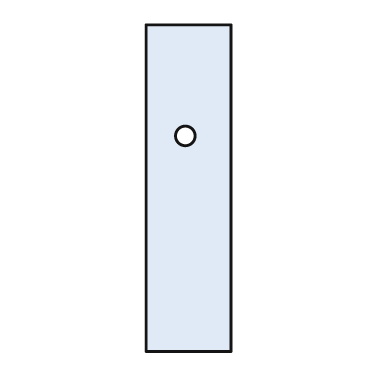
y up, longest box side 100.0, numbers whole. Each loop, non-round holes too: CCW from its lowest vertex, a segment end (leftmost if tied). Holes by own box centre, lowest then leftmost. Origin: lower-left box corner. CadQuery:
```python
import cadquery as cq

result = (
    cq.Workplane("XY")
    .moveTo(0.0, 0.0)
    .lineTo(26.0, 0.0)
    .lineTo(26.0, 100.0)
    .lineTo(0.0, 100.0)
    .close()
    .moveTo(12.0, 66.0)
    .circle(3.0)
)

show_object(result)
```